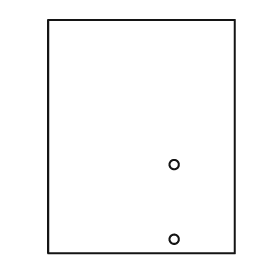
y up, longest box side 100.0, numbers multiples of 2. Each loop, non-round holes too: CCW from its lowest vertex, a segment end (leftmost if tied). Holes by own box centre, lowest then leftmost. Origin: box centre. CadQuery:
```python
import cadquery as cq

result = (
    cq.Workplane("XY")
    .moveTo(-40.0, -50.0)
    .lineTo(40.0, -50.0)
    .lineTo(40.0, 50.0)
    .lineTo(-40.0, 50.0)
    .close()
    .moveTo(14.0, -44.0)
    .circle(2.0)
    .moveTo(14.0, -12.0)
    .circle(2.0)
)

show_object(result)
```